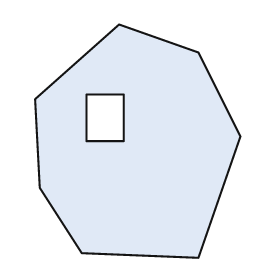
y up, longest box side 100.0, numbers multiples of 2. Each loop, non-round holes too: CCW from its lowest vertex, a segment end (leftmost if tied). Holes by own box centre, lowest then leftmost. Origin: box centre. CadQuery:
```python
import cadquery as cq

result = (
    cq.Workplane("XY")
    .moveTo(26.0, -50.0)
    .lineTo(44.0, 2.0)
    .lineTo(26.0, 38.0)
    .lineTo(-8.0, 50.0)
    .lineTo(-44.0, 18.0)
    .lineTo(-42.0, -20.0)
    .lineTo(-24.0, -48.0)
    .close()
    .moveTo(-22.0, 0.0)
    .lineTo(-6.0, 0.0)
    .lineTo(-6.0, 20.0)
    .lineTo(-22.0, 20.0)
    .close()
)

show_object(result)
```